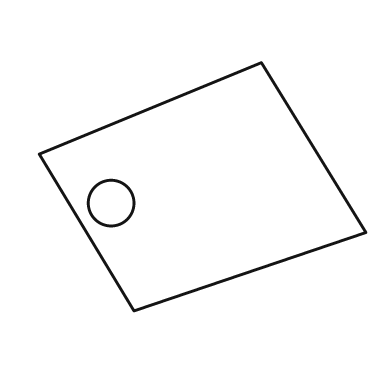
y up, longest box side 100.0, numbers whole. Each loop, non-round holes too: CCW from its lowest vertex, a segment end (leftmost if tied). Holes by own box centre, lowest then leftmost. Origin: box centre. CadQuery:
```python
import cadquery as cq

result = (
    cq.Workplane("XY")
    .moveTo(-21.0, -38.0)
    .lineTo(50.0, -14.0)
    .lineTo(18.0, 38.0)
    .lineTo(-50.0, 10.0)
    .close()
    .moveTo(-28.0, -5.0)
    .circle(7.0)
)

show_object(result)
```